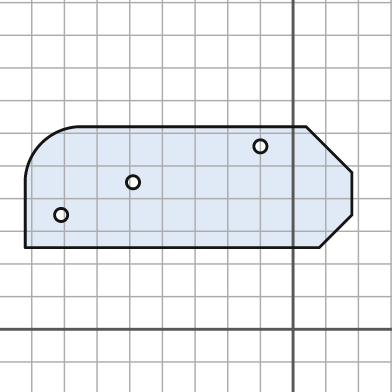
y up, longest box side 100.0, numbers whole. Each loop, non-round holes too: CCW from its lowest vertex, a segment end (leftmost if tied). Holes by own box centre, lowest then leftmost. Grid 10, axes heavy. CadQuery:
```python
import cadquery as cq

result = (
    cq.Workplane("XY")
    .moveTo(-82.0, 25.0)
    .lineTo(8.0, 25.0)
    .lineTo(18.0, 35.0)
    .lineTo(18.0, 48.0)
    .lineTo(4.0, 62.0)
    .lineTo(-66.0, 62.0)
    .threePointArc((-77.0, 57.0), (-82.0, 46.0))
    .close()
    .moveTo(-71.0, 35.0)
    .circle(2.0)
    .moveTo(-49.0, 45.0)
    .circle(2.0)
    .moveTo(-10.0, 56.0)
    .circle(2.0)
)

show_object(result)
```